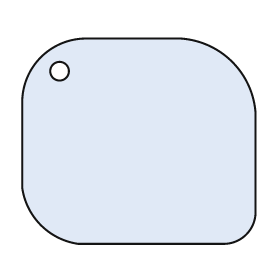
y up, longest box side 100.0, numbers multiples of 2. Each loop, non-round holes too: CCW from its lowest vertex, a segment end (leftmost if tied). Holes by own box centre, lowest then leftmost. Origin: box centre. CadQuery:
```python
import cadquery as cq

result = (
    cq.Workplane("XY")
    .moveTo(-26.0, -44.0)
    .lineTo(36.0, -44.0)
    .threePointArc((46.0, -40.0), (50.0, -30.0))
    .lineTo(50.0, 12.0)
    .threePointArc((40.0, 34.0), (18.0, 44.0))
    .lineTo(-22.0, 44.0)
    .threePointArc((-42.0, 36.0), (-50.0, 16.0))
    .lineTo(-50.0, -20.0)
    .threePointArc((-42.0, -36.0), (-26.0, -44.0))
    .close()
    .moveTo(-34.0, 30.0)
    .circle(4.0)
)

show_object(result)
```